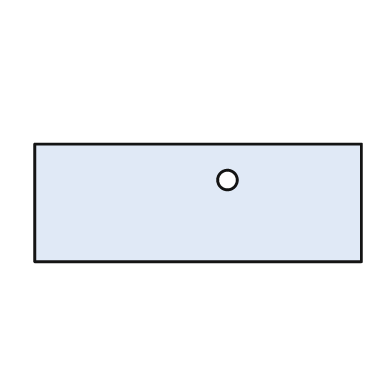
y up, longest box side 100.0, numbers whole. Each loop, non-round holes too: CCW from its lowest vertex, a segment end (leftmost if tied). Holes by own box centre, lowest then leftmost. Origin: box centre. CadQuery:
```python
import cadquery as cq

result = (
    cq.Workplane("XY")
    .moveTo(-50.0, -18.0)
    .lineTo(50.0, -18.0)
    .lineTo(50.0, 18.0)
    .lineTo(-50.0, 18.0)
    .close()
    .moveTo(9.0, 7.0)
    .circle(3.0)
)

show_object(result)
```